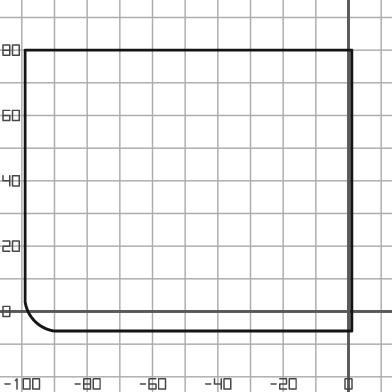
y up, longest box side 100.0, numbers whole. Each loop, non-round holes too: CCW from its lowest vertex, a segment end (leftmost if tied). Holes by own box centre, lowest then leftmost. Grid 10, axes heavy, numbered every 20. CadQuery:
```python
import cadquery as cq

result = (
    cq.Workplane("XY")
    .moveTo(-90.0, -6.0)
    .lineTo(1.0, -6.0)
    .lineTo(1.0, 80.0)
    .lineTo(-99.0, 80.0)
    .lineTo(-99.0, 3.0)
    .threePointArc((-96.0, -3.0), (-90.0, -6.0))
    .close()
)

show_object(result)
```